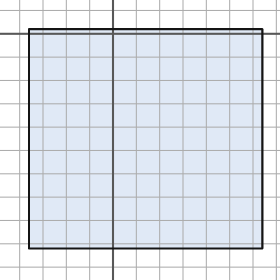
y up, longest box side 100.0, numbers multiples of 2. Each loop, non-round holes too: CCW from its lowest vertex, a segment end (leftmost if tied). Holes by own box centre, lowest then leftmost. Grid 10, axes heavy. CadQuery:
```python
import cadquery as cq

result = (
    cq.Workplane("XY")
    .moveTo(-36.0, -92.0)
    .lineTo(64.0, -92.0)
    .lineTo(64.0, 2.0)
    .lineTo(-36.0, 2.0)
    .close()
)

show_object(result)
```